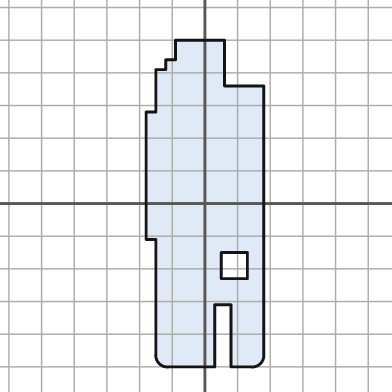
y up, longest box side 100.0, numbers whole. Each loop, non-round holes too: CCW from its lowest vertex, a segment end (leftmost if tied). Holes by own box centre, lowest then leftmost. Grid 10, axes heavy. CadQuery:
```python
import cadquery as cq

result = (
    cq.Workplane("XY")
    .moveTo(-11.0, -50.0)
    .lineTo(3.0, -50.0)
    .lineTo(3.0, -31.0)
    .lineTo(8.0, -31.0)
    .lineTo(8.0, -50.0)
    .lineTo(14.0, -50.0)
    .threePointArc((17.0, -49.0), (18.0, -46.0))
    .lineTo(18.0, 36.0)
    .lineTo(6.0, 36.0)
    .lineTo(6.0, 50.0)
    .lineTo(-9.0, 50.0)
    .lineTo(-9.0, 44.0)
    .lineTo(-12.0, 44.0)
    .lineTo(-12.0, 41.0)
    .lineTo(-15.0, 41.0)
    .lineTo(-15.0, 28.0)
    .lineTo(-18.0, 28.0)
    .lineTo(-18.0, -11.0)
    .lineTo(-15.0, -11.0)
    .lineTo(-15.0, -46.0)
    .threePointArc((-14.0, -49.0), (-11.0, -50.0))
    .close()
    .moveTo(5.0, -23.0)
    .lineTo(13.0, -23.0)
    .lineTo(13.0, -15.0)
    .lineTo(5.0, -15.0)
    .close()
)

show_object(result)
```